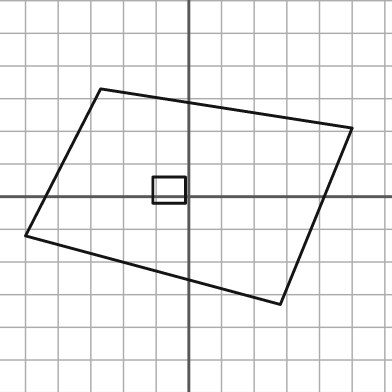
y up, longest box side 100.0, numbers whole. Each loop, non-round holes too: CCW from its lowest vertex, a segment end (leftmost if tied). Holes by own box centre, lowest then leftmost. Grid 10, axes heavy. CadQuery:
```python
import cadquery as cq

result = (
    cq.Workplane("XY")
    .moveTo(28.0, -33.0)
    .lineTo(50.0, 21.0)
    .lineTo(-27.0, 33.0)
    .lineTo(-50.0, -12.0)
    .close()
    .moveTo(-11.0, -2.0)
    .lineTo(-1.0, -2.0)
    .lineTo(-1.0, 6.0)
    .lineTo(-11.0, 6.0)
    .close()
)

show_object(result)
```